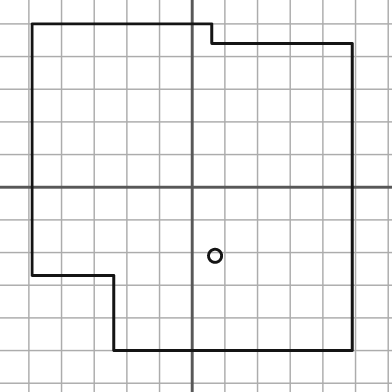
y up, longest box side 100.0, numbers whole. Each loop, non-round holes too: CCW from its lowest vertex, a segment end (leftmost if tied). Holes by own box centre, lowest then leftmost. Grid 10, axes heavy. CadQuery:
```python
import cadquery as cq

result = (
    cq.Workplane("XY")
    .moveTo(-24.0, -50.0)
    .lineTo(49.0, -50.0)
    .lineTo(49.0, 44.0)
    .lineTo(6.0, 44.0)
    .lineTo(6.0, 50.0)
    .lineTo(-49.0, 50.0)
    .lineTo(-49.0, -27.0)
    .lineTo(-24.0, -27.0)
    .close()
    .moveTo(7.0, -21.0)
    .circle(2.0)
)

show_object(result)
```